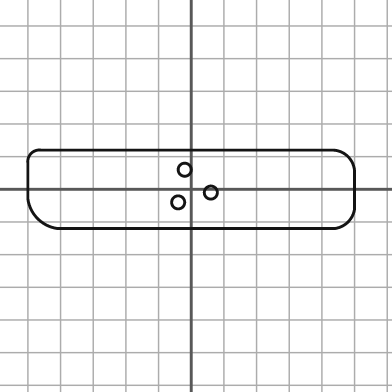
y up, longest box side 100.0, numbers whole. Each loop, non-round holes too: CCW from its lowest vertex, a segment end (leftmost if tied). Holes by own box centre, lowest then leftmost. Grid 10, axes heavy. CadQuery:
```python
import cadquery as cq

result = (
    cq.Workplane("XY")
    .moveTo(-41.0, -12.0)
    .lineTo(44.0, -12.0)
    .threePointArc((48.0, -10.0), (50.0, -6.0))
    .lineTo(50.0, 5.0)
    .threePointArc((48.0, 10.0), (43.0, 12.0))
    .lineTo(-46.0, 12.0)
    .threePointArc((-49.0, 11.0), (-50.0, 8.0))
    .lineTo(-50.0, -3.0)
    .threePointArc((-47.0, -9.0), (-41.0, -12.0))
    .close()
    .moveTo(-4.0, -4.0)
    .circle(2.0)
    .moveTo(6.0, -1.0)
    .circle(2.0)
    .moveTo(-2.0, 6.0)
    .circle(2.0)
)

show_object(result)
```